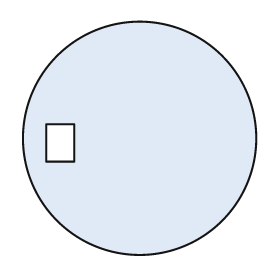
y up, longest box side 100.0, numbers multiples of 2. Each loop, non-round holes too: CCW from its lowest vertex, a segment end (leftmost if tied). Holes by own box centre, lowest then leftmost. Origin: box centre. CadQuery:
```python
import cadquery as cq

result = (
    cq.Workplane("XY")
    .moveTo(0.0, 0.0)
    .circle(50.0)
    .moveTo(-40.0, -10.0)
    .lineTo(-28.0, -10.0)
    .lineTo(-28.0, 6.0)
    .lineTo(-40.0, 6.0)
    .close()
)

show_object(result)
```